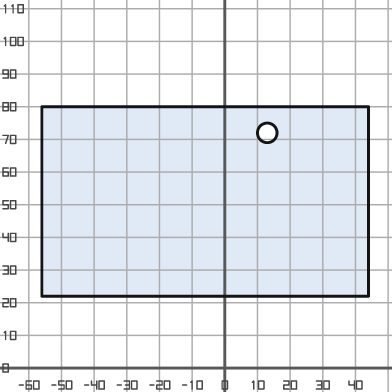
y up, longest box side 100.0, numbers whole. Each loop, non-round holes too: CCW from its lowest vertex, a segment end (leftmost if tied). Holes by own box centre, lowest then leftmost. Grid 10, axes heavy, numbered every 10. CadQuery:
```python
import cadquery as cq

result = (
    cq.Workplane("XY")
    .moveTo(-56.0, 22.0)
    .lineTo(44.0, 22.0)
    .lineTo(44.0, 80.0)
    .lineTo(-56.0, 80.0)
    .close()
    .moveTo(13.0, 72.0)
    .circle(3.0)
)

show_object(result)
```